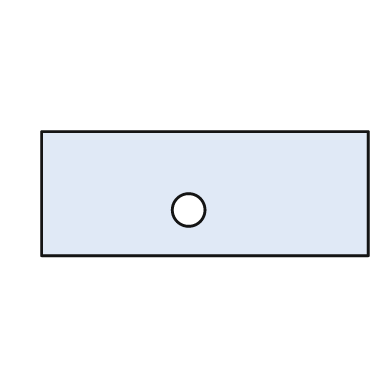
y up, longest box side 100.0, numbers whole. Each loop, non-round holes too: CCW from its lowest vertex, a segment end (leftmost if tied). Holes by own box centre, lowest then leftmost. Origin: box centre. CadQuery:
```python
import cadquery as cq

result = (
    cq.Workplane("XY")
    .moveTo(-50.0, -19.0)
    .lineTo(50.0, -19.0)
    .lineTo(50.0, 19.0)
    .lineTo(-50.0, 19.0)
    .close()
    .moveTo(-5.0, -5.0)
    .circle(5.0)
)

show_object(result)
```